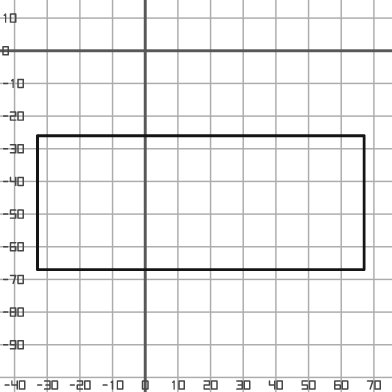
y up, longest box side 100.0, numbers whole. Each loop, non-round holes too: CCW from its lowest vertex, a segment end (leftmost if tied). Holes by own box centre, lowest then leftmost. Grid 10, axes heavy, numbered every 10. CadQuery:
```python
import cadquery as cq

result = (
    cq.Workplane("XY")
    .moveTo(-33.0, -67.0)
    .lineTo(67.0, -67.0)
    .lineTo(67.0, -26.0)
    .lineTo(-33.0, -26.0)
    .close()
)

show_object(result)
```